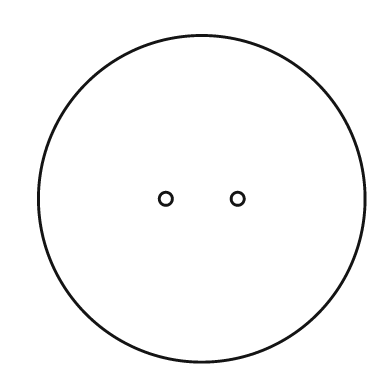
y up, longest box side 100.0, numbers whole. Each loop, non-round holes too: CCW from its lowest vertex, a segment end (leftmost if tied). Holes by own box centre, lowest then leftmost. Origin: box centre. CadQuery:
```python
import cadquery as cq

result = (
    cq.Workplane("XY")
    .moveTo(0.0, 0.0)
    .circle(50.0)
    .moveTo(-11.0, 0.0)
    .circle(2.0)
    .moveTo(11.0, 0.0)
    .circle(2.0)
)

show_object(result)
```